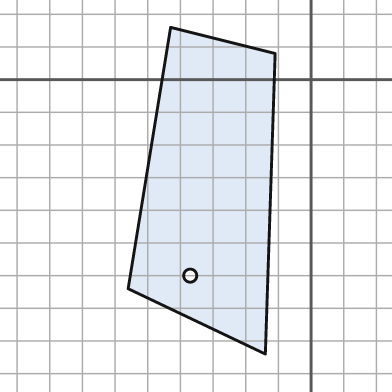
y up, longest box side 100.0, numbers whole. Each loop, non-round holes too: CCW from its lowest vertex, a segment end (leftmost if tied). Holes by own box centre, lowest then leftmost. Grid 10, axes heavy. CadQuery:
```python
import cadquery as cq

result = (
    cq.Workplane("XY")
    .moveTo(-14.0, -84.0)
    .lineTo(-11.0, 8.0)
    .lineTo(-43.0, 16.0)
    .lineTo(-56.0, -64.0)
    .close()
    .moveTo(-37.0, -60.0)
    .circle(2.0)
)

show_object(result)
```